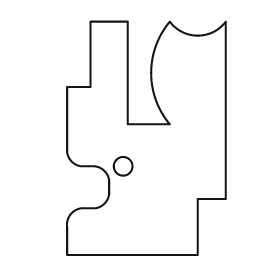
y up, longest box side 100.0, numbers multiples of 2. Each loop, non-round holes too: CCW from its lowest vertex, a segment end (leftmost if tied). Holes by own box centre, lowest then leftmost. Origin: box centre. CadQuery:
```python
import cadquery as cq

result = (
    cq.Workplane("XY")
    .moveTo(-34.0, -50.0)
    .lineTo(22.0, -50.0)
    .lineTo(22.0, -26.0)
    .lineTo(34.0, -26.0)
    .lineTo(34.0, 50.0)
    .threePointArc((22.0, 44.0), (10.0, 50.0))
    .threePointArc((2.0, 28.0), (10.0, 6.0))
    .lineTo(-8.0, 6.0)
    .lineTo(-8.0, 50.0)
    .lineTo(-24.0, 50.0)
    .lineTo(-24.0, 22.0)
    .lineTo(-34.0, 22.0)
    .lineTo(-34.0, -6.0)
    .threePointArc((-32.0, -10.0), (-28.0, -12.0))
    .lineTo(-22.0, -12.0)
    .threePointArc((-18.0, -14.0), (-16.0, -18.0))
    .lineTo(-16.0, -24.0)
    .threePointArc((-18.0, -28.0), (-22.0, -30.0))
    .lineTo(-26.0, -30.0)
    .threePointArc((-32.0, -32.0), (-34.0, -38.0))
    .close()
    .moveTo(-10.0, -12.0)
    .circle(4.0)
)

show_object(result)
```